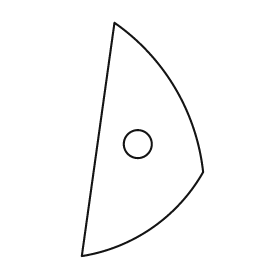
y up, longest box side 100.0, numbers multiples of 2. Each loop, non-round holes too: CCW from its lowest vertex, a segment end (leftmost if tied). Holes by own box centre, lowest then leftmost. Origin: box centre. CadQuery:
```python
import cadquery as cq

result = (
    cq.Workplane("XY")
    .moveTo(-26.0, -50.0)
    .threePointArc((4.0, -38.0), (26.0, -14.0))
    .threePointArc((14.0, 22.0), (-12.0, 50.0))
    .close()
    .moveTo(-2.0, -2.0)
    .circle(6.0)
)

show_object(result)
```